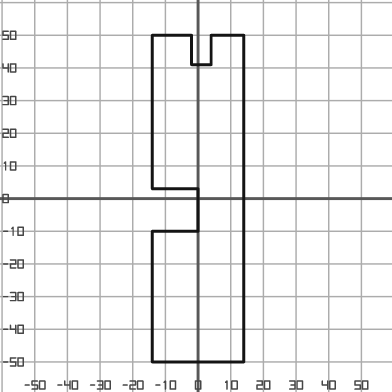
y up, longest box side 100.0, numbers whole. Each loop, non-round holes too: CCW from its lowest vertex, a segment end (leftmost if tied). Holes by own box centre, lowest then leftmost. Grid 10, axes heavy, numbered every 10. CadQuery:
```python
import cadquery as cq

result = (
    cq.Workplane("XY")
    .moveTo(-14.0, -50.0)
    .lineTo(14.0, -50.0)
    .lineTo(14.0, 50.0)
    .lineTo(4.0, 50.0)
    .lineTo(4.0, 41.0)
    .lineTo(-2.0, 41.0)
    .lineTo(-2.0, 50.0)
    .lineTo(-14.0, 50.0)
    .lineTo(-14.0, 3.0)
    .lineTo(0.0, 3.0)
    .lineTo(0.0, -10.0)
    .lineTo(-14.0, -10.0)
    .close()
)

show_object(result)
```